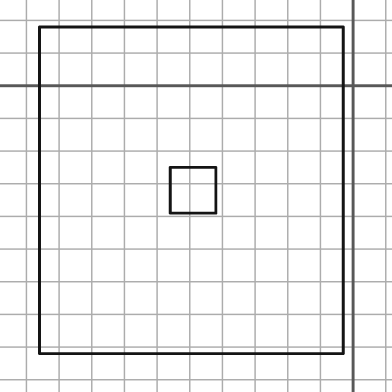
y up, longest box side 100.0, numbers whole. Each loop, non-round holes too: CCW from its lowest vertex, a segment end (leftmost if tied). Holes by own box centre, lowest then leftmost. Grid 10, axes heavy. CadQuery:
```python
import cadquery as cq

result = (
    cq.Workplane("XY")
    .moveTo(-96.0, -82.0)
    .lineTo(-3.0, -82.0)
    .lineTo(-3.0, 18.0)
    .lineTo(-96.0, 18.0)
    .close()
    .moveTo(-56.0, -39.0)
    .lineTo(-42.0, -39.0)
    .lineTo(-42.0, -25.0)
    .lineTo(-56.0, -25.0)
    .close()
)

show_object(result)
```